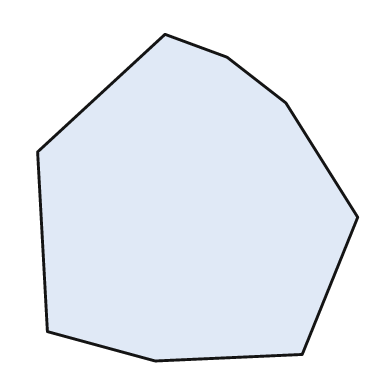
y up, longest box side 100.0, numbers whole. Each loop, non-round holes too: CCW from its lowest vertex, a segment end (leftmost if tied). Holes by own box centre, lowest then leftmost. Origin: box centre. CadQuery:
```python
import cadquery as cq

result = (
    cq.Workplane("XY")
    .moveTo(-13.0, -50.0)
    .lineTo(32.0, -48.0)
    .lineTo(49.0, -6.0)
    .lineTo(27.0, 29.0)
    .lineTo(9.0, 43.0)
    .lineTo(-10.0, 50.0)
    .lineTo(-49.0, 14.0)
    .lineTo(-46.0, -41.0)
    .close()
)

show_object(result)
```